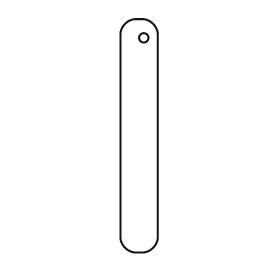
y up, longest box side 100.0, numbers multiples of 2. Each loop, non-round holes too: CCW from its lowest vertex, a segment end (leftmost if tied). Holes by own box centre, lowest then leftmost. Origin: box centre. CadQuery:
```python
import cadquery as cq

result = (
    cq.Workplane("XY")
    .moveTo(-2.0, -50.0)
    .lineTo(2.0, -50.0)
    .threePointArc((6.0, -48.0), (8.0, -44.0))
    .lineTo(8.0, 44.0)
    .threePointArc((6.0, 48.0), (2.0, 50.0))
    .lineTo(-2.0, 50.0)
    .threePointArc((-6.0, 48.0), (-8.0, 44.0))
    .lineTo(-8.0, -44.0)
    .threePointArc((-6.0, -48.0), (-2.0, -50.0))
    .close()
    .moveTo(2.0, 42.0)
    .circle(2.0)
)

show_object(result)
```